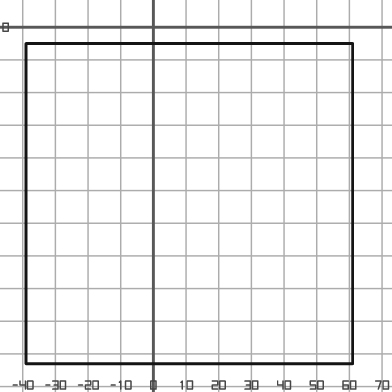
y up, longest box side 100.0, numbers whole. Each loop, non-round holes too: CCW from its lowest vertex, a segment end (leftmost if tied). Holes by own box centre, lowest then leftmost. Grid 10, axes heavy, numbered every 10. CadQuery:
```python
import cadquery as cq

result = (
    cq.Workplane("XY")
    .moveTo(-39.0, -103.0)
    .lineTo(61.0, -103.0)
    .lineTo(61.0, -5.0)
    .lineTo(-39.0, -5.0)
    .close()
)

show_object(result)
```